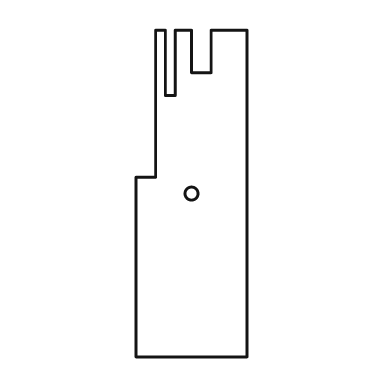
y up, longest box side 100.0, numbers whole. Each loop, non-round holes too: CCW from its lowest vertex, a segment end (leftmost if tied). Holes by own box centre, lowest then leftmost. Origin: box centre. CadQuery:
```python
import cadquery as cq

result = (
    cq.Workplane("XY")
    .moveTo(-17.0, -50.0)
    .lineTo(17.0, -50.0)
    .lineTo(17.0, 50.0)
    .lineTo(6.0, 50.0)
    .lineTo(6.0, 37.0)
    .lineTo(0.0, 37.0)
    .lineTo(0.0, 50.0)
    .lineTo(-5.0, 50.0)
    .lineTo(-5.0, 30.0)
    .lineTo(-8.0, 30.0)
    .lineTo(-8.0, 50.0)
    .lineTo(-11.0, 50.0)
    .lineTo(-11.0, 5.0)
    .lineTo(-17.0, 5.0)
    .close()
    .moveTo(0.0, 0.0)
    .circle(2.0)
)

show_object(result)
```